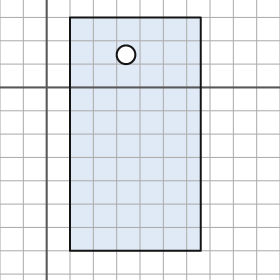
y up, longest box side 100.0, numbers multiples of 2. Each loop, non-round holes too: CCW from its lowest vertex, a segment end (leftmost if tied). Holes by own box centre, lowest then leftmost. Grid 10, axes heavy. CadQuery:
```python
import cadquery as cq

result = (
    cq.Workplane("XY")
    .moveTo(10.0, -70.0)
    .lineTo(66.0, -70.0)
    .lineTo(66.0, 30.0)
    .lineTo(10.0, 30.0)
    .close()
    .moveTo(34.0, 14.0)
    .circle(4.0)
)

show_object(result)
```